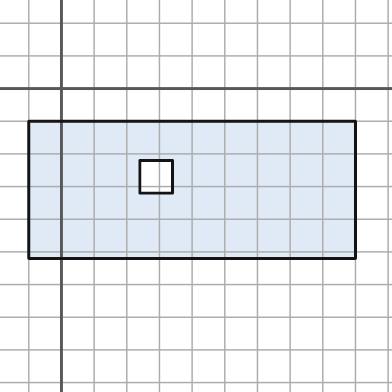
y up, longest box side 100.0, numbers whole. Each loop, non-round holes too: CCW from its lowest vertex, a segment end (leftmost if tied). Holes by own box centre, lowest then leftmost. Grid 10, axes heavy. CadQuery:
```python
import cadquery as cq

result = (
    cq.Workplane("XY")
    .moveTo(-10.0, -52.0)
    .lineTo(90.0, -52.0)
    .lineTo(90.0, -10.0)
    .lineTo(-10.0, -10.0)
    .close()
    .moveTo(24.0, -32.0)
    .lineTo(34.0, -32.0)
    .lineTo(34.0, -22.0)
    .lineTo(24.0, -22.0)
    .close()
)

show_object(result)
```